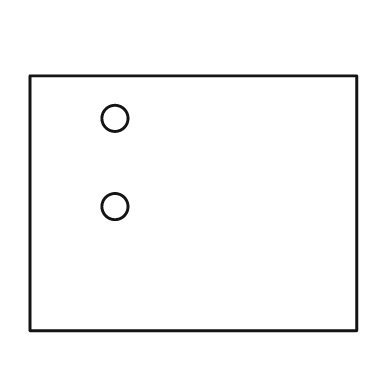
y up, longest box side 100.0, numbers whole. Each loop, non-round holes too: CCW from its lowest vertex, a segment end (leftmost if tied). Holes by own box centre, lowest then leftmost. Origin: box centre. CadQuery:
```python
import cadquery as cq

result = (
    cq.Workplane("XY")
    .moveTo(-50.0, -39.0)
    .lineTo(50.0, -39.0)
    .lineTo(50.0, 39.0)
    .lineTo(-50.0, 39.0)
    .close()
    .moveTo(-24.0, -1.0)
    .circle(4.0)
    .moveTo(-24.0, 26.0)
    .circle(4.0)
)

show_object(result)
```